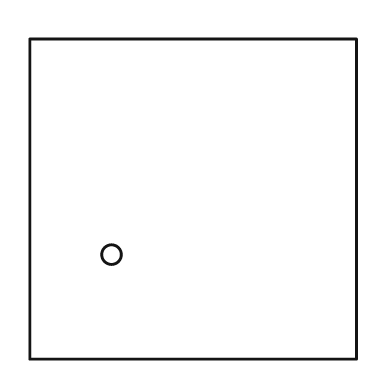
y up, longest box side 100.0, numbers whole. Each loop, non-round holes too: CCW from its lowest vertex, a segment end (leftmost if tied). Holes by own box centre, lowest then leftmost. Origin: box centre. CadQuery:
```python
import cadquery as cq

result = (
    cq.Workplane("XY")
    .moveTo(-50.0, -49.0)
    .lineTo(50.0, -49.0)
    .lineTo(50.0, 49.0)
    .lineTo(-50.0, 49.0)
    .close()
    .moveTo(-25.0, -17.0)
    .circle(3.0)
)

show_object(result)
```